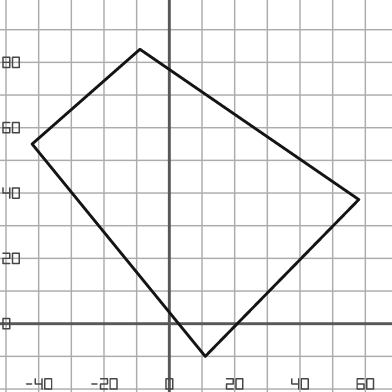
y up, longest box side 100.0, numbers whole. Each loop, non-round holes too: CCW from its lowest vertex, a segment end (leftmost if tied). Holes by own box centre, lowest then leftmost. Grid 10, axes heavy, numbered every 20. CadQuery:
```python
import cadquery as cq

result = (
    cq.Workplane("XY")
    .moveTo(11.0, -10.0)
    .lineTo(58.0, 38.0)
    .lineTo(-9.0, 84.0)
    .lineTo(-42.0, 55.0)
    .close()
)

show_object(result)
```